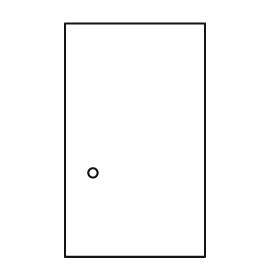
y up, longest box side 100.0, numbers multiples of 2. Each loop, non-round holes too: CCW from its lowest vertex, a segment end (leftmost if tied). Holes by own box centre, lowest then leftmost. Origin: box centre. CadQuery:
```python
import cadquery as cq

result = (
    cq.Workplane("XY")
    .moveTo(-30.0, -50.0)
    .lineTo(30.0, -50.0)
    .lineTo(30.0, 50.0)
    .lineTo(-30.0, 50.0)
    .close()
    .moveTo(-18.0, -14.0)
    .circle(2.0)
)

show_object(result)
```